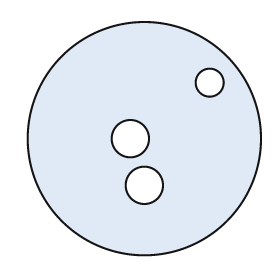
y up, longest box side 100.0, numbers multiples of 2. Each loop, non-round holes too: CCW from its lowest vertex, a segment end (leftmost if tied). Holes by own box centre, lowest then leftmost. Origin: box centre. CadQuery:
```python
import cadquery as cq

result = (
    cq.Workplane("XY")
    .moveTo(0.0, 0.0)
    .circle(50.0)
    .moveTo(0.0, -20.0)
    .circle(8.0)
    .moveTo(-6.0, 0.0)
    .circle(8.0)
    .moveTo(28.0, 24.0)
    .circle(6.0)
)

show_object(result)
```